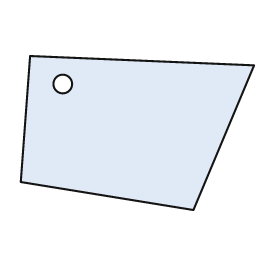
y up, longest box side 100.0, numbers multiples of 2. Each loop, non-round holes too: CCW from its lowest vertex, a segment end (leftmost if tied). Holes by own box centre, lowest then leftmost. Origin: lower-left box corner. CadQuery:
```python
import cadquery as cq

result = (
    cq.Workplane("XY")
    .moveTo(74.0, 0.0)
    .lineTo(100.0, 62.0)
    .lineTo(4.0, 66.0)
    .lineTo(0.0, 12.0)
    .close()
    .moveTo(18.0, 54.0)
    .circle(4.0)
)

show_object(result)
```